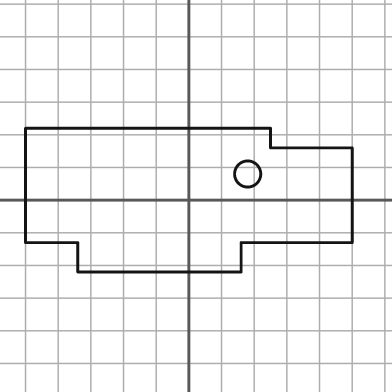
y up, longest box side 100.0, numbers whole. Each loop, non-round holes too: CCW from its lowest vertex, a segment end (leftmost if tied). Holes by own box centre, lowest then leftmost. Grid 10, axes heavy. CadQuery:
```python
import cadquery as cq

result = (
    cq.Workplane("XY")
    .moveTo(-34.0, -22.0)
    .lineTo(16.0, -22.0)
    .lineTo(16.0, -13.0)
    .lineTo(50.0, -13.0)
    .lineTo(50.0, 16.0)
    .lineTo(25.0, 16.0)
    .lineTo(25.0, 22.0)
    .lineTo(-50.0, 22.0)
    .lineTo(-50.0, -13.0)
    .lineTo(-34.0, -13.0)
    .close()
    .moveTo(18.0, 8.0)
    .circle(4.0)
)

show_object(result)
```